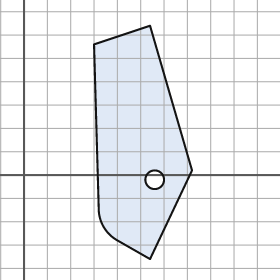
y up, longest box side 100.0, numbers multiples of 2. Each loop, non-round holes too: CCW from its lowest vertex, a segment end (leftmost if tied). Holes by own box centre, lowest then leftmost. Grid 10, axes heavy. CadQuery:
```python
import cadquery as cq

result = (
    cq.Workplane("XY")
    .moveTo(54.0, -36.0)
    .lineTo(72.0, 2.0)
    .lineTo(54.0, 64.0)
    .lineTo(30.0, 56.0)
    .lineTo(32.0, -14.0)
    .threePointArc((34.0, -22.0), (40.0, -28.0))
    .close()
    .moveTo(56.0, -2.0)
    .circle(4.0)
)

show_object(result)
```